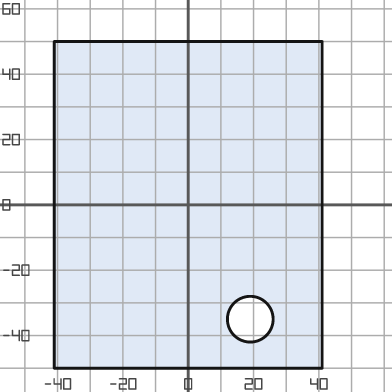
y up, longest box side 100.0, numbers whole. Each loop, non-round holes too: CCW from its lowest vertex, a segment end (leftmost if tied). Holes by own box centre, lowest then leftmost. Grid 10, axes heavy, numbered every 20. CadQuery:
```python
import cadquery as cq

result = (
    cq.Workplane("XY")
    .moveTo(-41.0, -50.0)
    .lineTo(41.0, -50.0)
    .lineTo(41.0, 50.0)
    .lineTo(-41.0, 50.0)
    .close()
    .moveTo(19.0, -35.0)
    .circle(7.0)
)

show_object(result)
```